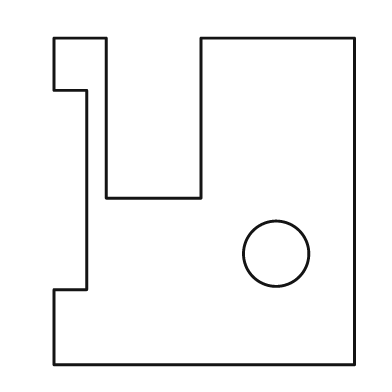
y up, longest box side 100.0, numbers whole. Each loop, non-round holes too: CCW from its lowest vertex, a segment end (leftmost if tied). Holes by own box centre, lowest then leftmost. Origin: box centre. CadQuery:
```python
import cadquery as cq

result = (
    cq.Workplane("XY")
    .moveTo(-46.0, -50.0)
    .lineTo(46.0, -50.0)
    .lineTo(46.0, 50.0)
    .lineTo(-1.0, 50.0)
    .lineTo(-1.0, 1.0)
    .lineTo(-30.0, 1.0)
    .lineTo(-30.0, 50.0)
    .lineTo(-46.0, 50.0)
    .lineTo(-46.0, 34.0)
    .lineTo(-36.0, 34.0)
    .lineTo(-36.0, -27.0)
    .lineTo(-46.0, -27.0)
    .close()
    .moveTo(22.0, -16.0)
    .circle(10.0)
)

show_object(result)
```